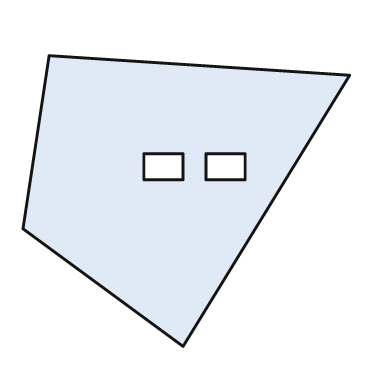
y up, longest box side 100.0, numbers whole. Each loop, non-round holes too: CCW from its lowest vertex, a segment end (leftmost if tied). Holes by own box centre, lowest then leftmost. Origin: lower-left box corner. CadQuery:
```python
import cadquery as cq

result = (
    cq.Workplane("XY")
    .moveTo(49.0, 0.0)
    .lineTo(100.0, 83.0)
    .lineTo(8.0, 89.0)
    .lineTo(0.0, 36.0)
    .close()
    .moveTo(37.0, 51.0)
    .lineTo(49.0, 51.0)
    .lineTo(49.0, 59.0)
    .lineTo(37.0, 59.0)
    .close()
    .moveTo(56.0, 51.0)
    .lineTo(68.0, 51.0)
    .lineTo(68.0, 59.0)
    .lineTo(56.0, 59.0)
    .close()
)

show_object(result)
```